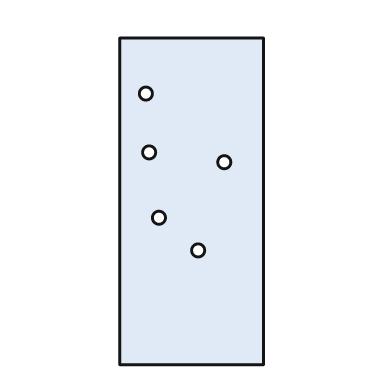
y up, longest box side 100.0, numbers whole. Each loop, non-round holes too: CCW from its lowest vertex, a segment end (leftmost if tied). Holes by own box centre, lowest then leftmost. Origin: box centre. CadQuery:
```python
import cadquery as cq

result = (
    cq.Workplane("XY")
    .moveTo(-22.0, -50.0)
    .lineTo(22.0, -50.0)
    .lineTo(22.0, 50.0)
    .lineTo(-22.0, 50.0)
    .close()
    .moveTo(2.0, -15.0)
    .circle(2.0)
    .moveTo(-10.0, -5.0)
    .circle(2.0)
    .moveTo(10.0, 12.0)
    .circle(2.0)
    .moveTo(-13.0, 15.0)
    .circle(2.0)
    .moveTo(-14.0, 33.0)
    .circle(2.0)
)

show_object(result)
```